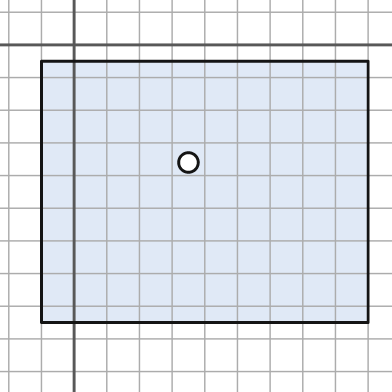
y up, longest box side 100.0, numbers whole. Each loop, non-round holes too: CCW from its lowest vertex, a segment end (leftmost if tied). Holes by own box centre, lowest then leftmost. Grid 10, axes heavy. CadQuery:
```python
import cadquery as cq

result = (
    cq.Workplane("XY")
    .moveTo(-10.0, -85.0)
    .lineTo(90.0, -85.0)
    .lineTo(90.0, -5.0)
    .lineTo(-10.0, -5.0)
    .close()
    .moveTo(35.0, -36.0)
    .circle(3.0)
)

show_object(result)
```